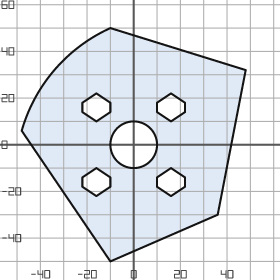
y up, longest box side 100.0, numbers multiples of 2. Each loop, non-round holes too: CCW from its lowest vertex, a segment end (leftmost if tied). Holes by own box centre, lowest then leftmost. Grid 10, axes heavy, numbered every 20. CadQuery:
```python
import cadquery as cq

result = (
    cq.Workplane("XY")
    .moveTo(-10.0, -50.0)
    .lineTo(36.0, -30.0)
    .lineTo(48.0, 32.0)
    .lineTo(-10.0, 50.0)
    .threePointArc((-34.0, 32.0), (-48.0, 6.0))
    .close()
    .moveTo(-16.0, -22.0)
    .lineTo(-10.0, -18.0)
    .lineTo(-10.0, -14.0)
    .lineTo(-16.0, -10.0)
    .lineTo(-22.0, -14.0)
    .lineTo(-22.0, -18.0)
    .close()
    .moveTo(16.0, -22.0)
    .lineTo(22.0, -18.0)
    .lineTo(22.0, -14.0)
    .lineTo(16.0, -10.0)
    .lineTo(10.0, -14.0)
    .lineTo(10.0, -18.0)
    .close()
    .moveTo(0.0, 0.0)
    .circle(10.0)
    .moveTo(-16.0, 10.0)
    .lineTo(-10.0, 14.0)
    .lineTo(-10.0, 18.0)
    .lineTo(-16.0, 22.0)
    .lineTo(-22.0, 18.0)
    .lineTo(-22.0, 14.0)
    .close()
    .moveTo(16.0, 10.0)
    .lineTo(22.0, 14.0)
    .lineTo(22.0, 18.0)
    .lineTo(16.0, 22.0)
    .lineTo(10.0, 18.0)
    .lineTo(10.0, 14.0)
    .close()
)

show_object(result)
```